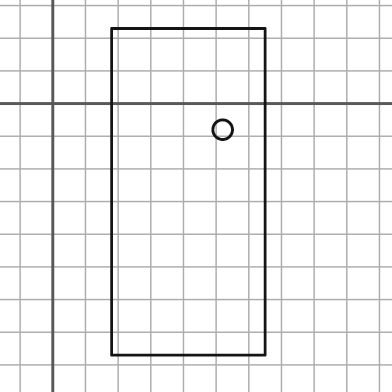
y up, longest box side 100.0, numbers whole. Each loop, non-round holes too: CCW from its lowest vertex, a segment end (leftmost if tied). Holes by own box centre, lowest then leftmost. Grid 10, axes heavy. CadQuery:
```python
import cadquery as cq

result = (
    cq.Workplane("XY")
    .moveTo(18.0, -77.0)
    .lineTo(65.0, -77.0)
    .lineTo(65.0, 23.0)
    .lineTo(18.0, 23.0)
    .close()
    .moveTo(52.0, -8.0)
    .circle(3.0)
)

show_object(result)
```